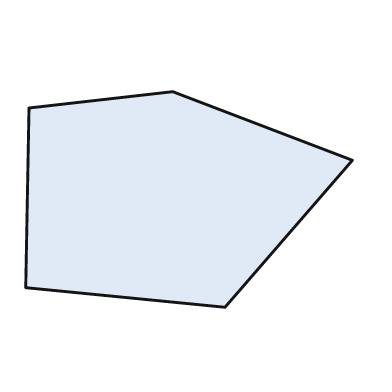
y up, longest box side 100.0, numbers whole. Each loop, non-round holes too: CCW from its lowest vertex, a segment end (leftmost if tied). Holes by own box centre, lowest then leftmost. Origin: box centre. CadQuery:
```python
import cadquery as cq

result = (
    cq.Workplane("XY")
    .moveTo(11.0, -33.0)
    .lineTo(50.0, 12.0)
    .lineTo(-5.0, 33.0)
    .lineTo(-49.0, 28.0)
    .lineTo(-50.0, -27.0)
    .close()
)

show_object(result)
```